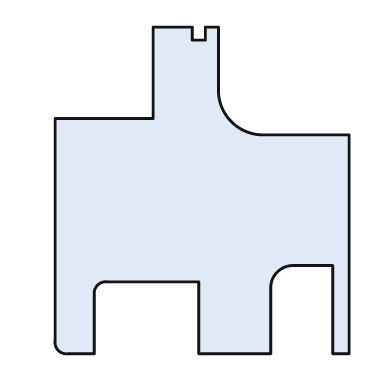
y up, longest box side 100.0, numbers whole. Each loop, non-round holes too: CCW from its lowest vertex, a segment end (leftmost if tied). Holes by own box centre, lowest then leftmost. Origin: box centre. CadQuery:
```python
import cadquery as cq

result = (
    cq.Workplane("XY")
    .moveTo(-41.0, -50.0)
    .lineTo(-33.0, -50.0)
    .lineTo(-33.0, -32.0)
    .threePointArc((-32.0, -29.0), (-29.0, -28.0))
    .lineTo(-1.0, -28.0)
    .lineTo(-1.0, -50.0)
    .lineTo(21.0, -50.0)
    .lineTo(21.0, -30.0)
    .threePointArc((23.0, -25.0), (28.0, -23.0))
    .lineTo(40.0, -23.0)
    .lineTo(40.0, -50.0)
    .lineTo(45.0, -50.0)
    .lineTo(45.0, 17.0)
    .lineTo(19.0, 17.0)
    .threePointArc((9.0, 21.0), (5.0, 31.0))
    .lineTo(5.0, 50.0)
    .lineTo(1.0, 50.0)
    .lineTo(1.0, 46.0)
    .lineTo(-3.0, 46.0)
    .lineTo(-3.0, 50.0)
    .lineTo(-15.0, 50.0)
    .lineTo(-15.0, 22.0)
    .lineTo(-45.0, 22.0)
    .lineTo(-45.0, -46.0)
    .threePointArc((-44.0, -49.0), (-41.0, -50.0))
    .close()
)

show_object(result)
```